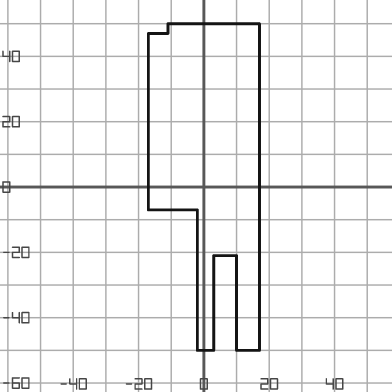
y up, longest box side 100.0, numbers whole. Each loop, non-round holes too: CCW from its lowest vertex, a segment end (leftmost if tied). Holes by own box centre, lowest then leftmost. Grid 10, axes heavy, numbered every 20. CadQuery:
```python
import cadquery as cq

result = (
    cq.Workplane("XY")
    .moveTo(-2.0, -50.0)
    .lineTo(3.0, -50.0)
    .lineTo(3.0, -21.0)
    .lineTo(10.0, -21.0)
    .lineTo(10.0, -50.0)
    .lineTo(17.0, -50.0)
    .lineTo(17.0, 50.0)
    .lineTo(-11.0, 50.0)
    .lineTo(-11.0, 47.0)
    .lineTo(-17.0, 47.0)
    .lineTo(-17.0, -7.0)
    .lineTo(-2.0, -7.0)
    .close()
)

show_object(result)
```